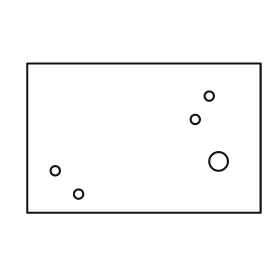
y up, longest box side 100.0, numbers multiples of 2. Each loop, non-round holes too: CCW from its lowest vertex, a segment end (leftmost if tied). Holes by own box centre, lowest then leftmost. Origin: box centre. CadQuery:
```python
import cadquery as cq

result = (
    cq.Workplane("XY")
    .moveTo(-50.0, -32.0)
    .lineTo(50.0, -32.0)
    .lineTo(50.0, 32.0)
    .lineTo(-50.0, 32.0)
    .close()
    .moveTo(-28.0, -24.0)
    .circle(2.0)
    .moveTo(-38.0, -14.0)
    .circle(2.0)
    .moveTo(32.0, -10.0)
    .circle(4.0)
    .moveTo(22.0, 8.0)
    .circle(2.0)
    .moveTo(28.0, 18.0)
    .circle(2.0)
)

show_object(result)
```